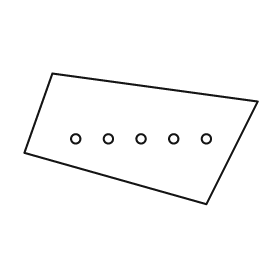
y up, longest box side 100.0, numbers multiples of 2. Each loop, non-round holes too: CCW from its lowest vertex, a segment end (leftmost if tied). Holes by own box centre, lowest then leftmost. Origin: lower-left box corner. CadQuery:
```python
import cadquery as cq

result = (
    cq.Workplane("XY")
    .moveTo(78.0, 0.0)
    .lineTo(100.0, 44.0)
    .lineTo(12.0, 56.0)
    .lineTo(0.0, 22.0)
    .close()
    .moveTo(22.0, 28.0)
    .circle(2.0)
    .moveTo(36.0, 28.0)
    .circle(2.0)
    .moveTo(50.0, 28.0)
    .circle(2.0)
    .moveTo(64.0, 28.0)
    .circle(2.0)
    .moveTo(78.0, 28.0)
    .circle(2.0)
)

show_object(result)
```